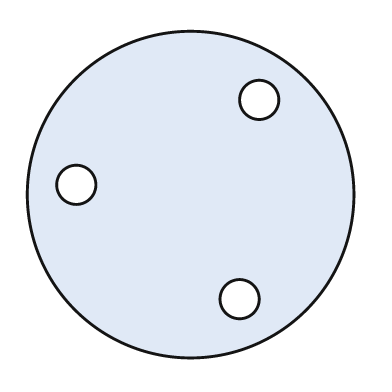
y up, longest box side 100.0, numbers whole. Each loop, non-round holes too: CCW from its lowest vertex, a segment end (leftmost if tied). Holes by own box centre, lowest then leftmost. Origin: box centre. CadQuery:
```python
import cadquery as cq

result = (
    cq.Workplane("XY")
    .moveTo(0.0, 0.0)
    .circle(50.0)
    .moveTo(15.0, -32.0)
    .circle(6.0)
    .moveTo(-35.0, 3.0)
    .circle(6.0)
    .moveTo(21.0, 29.0)
    .circle(6.0)
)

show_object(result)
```